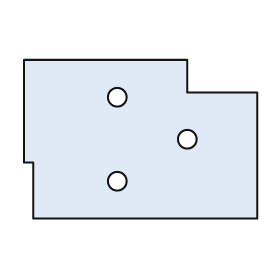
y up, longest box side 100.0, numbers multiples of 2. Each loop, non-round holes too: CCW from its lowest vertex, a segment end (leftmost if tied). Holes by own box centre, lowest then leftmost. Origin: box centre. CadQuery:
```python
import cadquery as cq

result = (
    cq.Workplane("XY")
    .moveTo(-46.0, -34.0)
    .lineTo(50.0, -34.0)
    .lineTo(50.0, 20.0)
    .lineTo(20.0, 20.0)
    .lineTo(20.0, 34.0)
    .lineTo(-50.0, 34.0)
    .lineTo(-50.0, -10.0)
    .lineTo(-46.0, -10.0)
    .close()
    .moveTo(-10.0, -18.0)
    .circle(4.0)
    .moveTo(20.0, 0.0)
    .circle(4.0)
    .moveTo(-10.0, 18.0)
    .circle(4.0)
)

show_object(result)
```